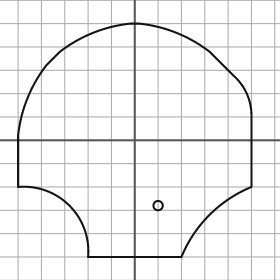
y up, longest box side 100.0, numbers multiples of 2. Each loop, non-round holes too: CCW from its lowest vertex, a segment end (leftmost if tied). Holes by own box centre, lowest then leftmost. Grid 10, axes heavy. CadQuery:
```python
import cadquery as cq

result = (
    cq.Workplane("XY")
    .moveTo(-20.0, -50.0)
    .lineTo(20.0, -50.0)
    .threePointArc((32.0, -32.0), (50.0, -20.0))
    .lineTo(50.0, 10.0)
    .threePointArc((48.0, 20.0), (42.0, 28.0))
    .lineTo(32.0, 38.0)
    .threePointArc((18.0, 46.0), (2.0, 50.0))
    .lineTo(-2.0, 50.0)
    .threePointArc((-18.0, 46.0), (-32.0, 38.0))
    .lineTo(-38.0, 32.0)
    .threePointArc((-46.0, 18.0), (-50.0, 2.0))
    .lineTo(-50.0, -20.0)
    .threePointArc((-28.0, -28.0), (-20.0, -50.0))
    .close()
    .moveTo(10.0, -28.0)
    .circle(2.0)
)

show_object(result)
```